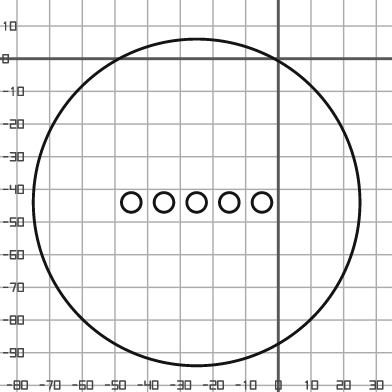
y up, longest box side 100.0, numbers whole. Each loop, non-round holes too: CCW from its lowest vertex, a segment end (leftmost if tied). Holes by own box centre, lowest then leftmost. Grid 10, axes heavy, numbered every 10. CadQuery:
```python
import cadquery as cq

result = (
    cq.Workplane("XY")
    .moveTo(-25.0, -44.0)
    .circle(50.0)
    .moveTo(-45.0, -44.0)
    .circle(3.0)
    .moveTo(-35.0, -44.0)
    .circle(3.0)
    .moveTo(-25.0, -44.0)
    .circle(3.0)
    .moveTo(-15.0, -44.0)
    .circle(3.0)
    .moveTo(-5.0, -44.0)
    .circle(3.0)
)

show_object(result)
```